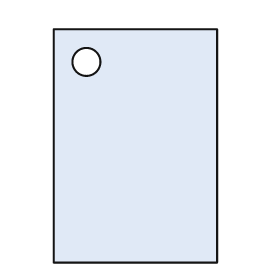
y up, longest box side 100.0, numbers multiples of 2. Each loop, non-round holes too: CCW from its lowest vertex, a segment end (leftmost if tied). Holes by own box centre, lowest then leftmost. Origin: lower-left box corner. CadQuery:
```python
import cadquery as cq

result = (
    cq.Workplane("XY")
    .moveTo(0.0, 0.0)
    .lineTo(70.0, 0.0)
    .lineTo(70.0, 100.0)
    .lineTo(0.0, 100.0)
    .close()
    .moveTo(14.0, 86.0)
    .circle(6.0)
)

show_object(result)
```